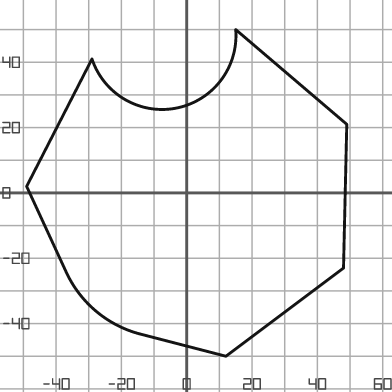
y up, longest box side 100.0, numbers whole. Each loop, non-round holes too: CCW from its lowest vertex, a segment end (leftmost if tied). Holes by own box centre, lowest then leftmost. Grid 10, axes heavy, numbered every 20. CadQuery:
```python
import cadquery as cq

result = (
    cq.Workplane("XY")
    .moveTo(12.0, -50.0)
    .lineTo(48.0, -23.0)
    .lineTo(49.0, 21.0)
    .lineTo(15.0, 50.0)
    .threePointArc((-3.0, 26.0), (-29.0, 41.0))
    .lineTo(-49.0, 2.0)
    .lineTo(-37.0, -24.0)
    .threePointArc((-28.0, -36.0), (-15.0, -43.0))
    .close()
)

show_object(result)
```